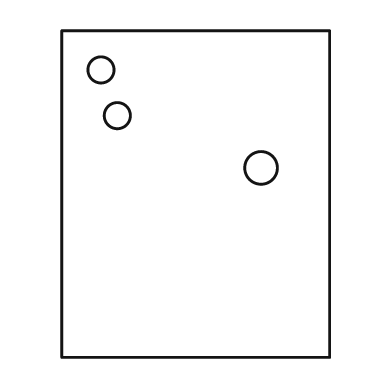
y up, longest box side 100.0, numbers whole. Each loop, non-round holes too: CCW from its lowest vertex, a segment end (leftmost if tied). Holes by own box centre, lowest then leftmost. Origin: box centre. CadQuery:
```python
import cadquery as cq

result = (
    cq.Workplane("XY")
    .moveTo(-41.0, -50.0)
    .lineTo(41.0, -50.0)
    .lineTo(41.0, 50.0)
    .lineTo(-41.0, 50.0)
    .close()
    .moveTo(20.0, 8.0)
    .circle(5.0)
    .moveTo(-24.0, 24.0)
    .circle(4.0)
    .moveTo(-29.0, 38.0)
    .circle(4.0)
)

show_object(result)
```